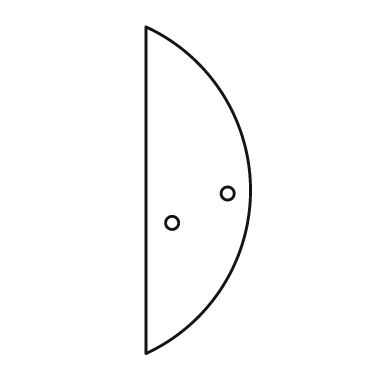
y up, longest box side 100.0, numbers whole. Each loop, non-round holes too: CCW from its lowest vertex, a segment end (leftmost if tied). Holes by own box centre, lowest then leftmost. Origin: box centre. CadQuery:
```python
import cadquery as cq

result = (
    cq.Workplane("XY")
    .moveTo(-16.0, -50.0)
    .threePointArc((16.0, 0.0), (-16.0, 50.0))
    .close()
    .moveTo(-8.0, -10.0)
    .circle(2.0)
    .moveTo(9.0, -1.0)
    .circle(2.0)
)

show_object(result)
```